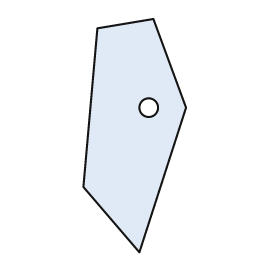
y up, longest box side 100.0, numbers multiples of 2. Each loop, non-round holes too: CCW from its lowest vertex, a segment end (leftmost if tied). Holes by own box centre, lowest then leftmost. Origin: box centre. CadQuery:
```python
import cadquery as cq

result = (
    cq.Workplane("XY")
    .moveTo(2.0, -50.0)
    .lineTo(22.0, 12.0)
    .lineTo(8.0, 50.0)
    .lineTo(-16.0, 46.0)
    .lineTo(-22.0, -22.0)
    .close()
    .moveTo(6.0, 12.0)
    .circle(4.0)
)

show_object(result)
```